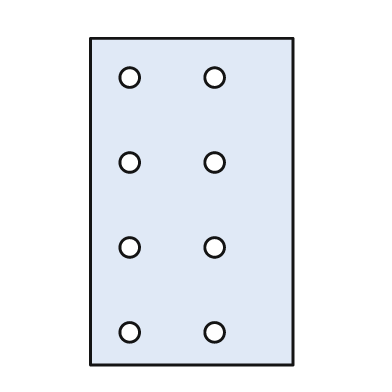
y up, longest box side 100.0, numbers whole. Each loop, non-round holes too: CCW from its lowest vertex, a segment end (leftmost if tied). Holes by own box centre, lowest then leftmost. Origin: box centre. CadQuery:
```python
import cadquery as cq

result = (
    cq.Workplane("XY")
    .moveTo(-31.0, -50.0)
    .lineTo(31.0, -50.0)
    .lineTo(31.0, 50.0)
    .lineTo(-31.0, 50.0)
    .close()
    .moveTo(-19.0, -40.0)
    .circle(3.0)
    .moveTo(7.0, -40.0)
    .circle(3.0)
    .moveTo(-19.0, -14.0)
    .circle(3.0)
    .moveTo(7.0, -14.0)
    .circle(3.0)
    .moveTo(-19.0, 12.0)
    .circle(3.0)
    .moveTo(7.0, 12.0)
    .circle(3.0)
    .moveTo(-19.0, 38.0)
    .circle(3.0)
    .moveTo(7.0, 38.0)
    .circle(3.0)
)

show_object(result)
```